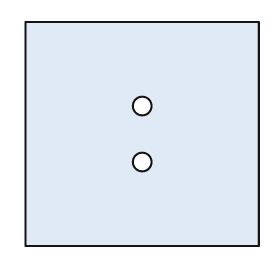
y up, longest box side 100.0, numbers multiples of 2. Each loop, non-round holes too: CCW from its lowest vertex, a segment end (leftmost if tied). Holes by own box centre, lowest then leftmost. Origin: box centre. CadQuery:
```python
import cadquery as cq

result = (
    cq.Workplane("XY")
    .moveTo(-50.0, -48.0)
    .lineTo(50.0, -48.0)
    .lineTo(50.0, 48.0)
    .lineTo(-50.0, 48.0)
    .close()
    .moveTo(0.0, -12.0)
    .circle(4.0)
    .moveTo(0.0, 12.0)
    .circle(4.0)
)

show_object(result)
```